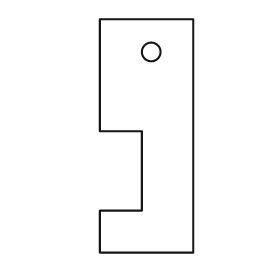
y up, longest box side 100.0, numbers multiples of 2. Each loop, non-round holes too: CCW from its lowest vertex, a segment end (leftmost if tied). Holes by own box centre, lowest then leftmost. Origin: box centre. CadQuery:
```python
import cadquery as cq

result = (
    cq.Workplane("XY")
    .moveTo(-20.0, -50.0)
    .lineTo(20.0, -50.0)
    .lineTo(20.0, 50.0)
    .lineTo(-20.0, 50.0)
    .lineTo(-20.0, 2.0)
    .lineTo(-2.0, 2.0)
    .lineTo(-2.0, -32.0)
    .lineTo(-20.0, -32.0)
    .close()
    .moveTo(2.0, 36.0)
    .circle(4.0)
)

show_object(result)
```